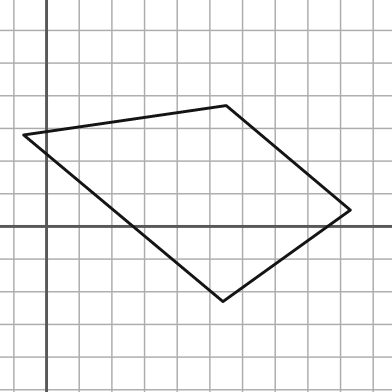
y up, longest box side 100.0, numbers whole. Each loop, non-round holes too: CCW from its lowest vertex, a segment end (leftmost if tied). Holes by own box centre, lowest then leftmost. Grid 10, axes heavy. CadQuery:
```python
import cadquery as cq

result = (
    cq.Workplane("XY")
    .moveTo(54.0, -23.0)
    .lineTo(93.0, 5.0)
    .lineTo(55.0, 37.0)
    .lineTo(-7.0, 28.0)
    .close()
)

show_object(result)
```